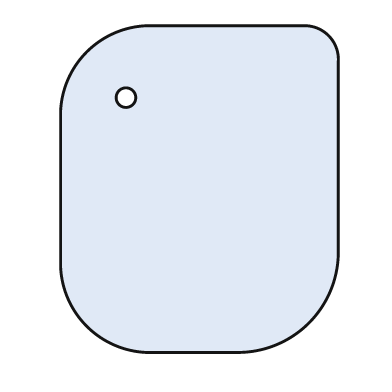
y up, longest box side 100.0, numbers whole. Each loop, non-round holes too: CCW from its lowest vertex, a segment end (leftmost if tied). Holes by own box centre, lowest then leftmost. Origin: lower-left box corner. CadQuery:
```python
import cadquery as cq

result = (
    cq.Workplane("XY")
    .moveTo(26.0, 0.0)
    .lineTo(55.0, 0.0)
    .threePointArc((76.0, 9.0), (85.0, 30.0))
    .lineTo(85.0, 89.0)
    .threePointArc((82.0, 97.0), (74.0, 100.0))
    .lineTo(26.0, 100.0)
    .threePointArc((8.0, 92.0), (0.0, 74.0))
    .lineTo(0.0, 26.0)
    .threePointArc((8.0, 8.0), (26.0, 0.0))
    .close()
    .moveTo(20.0, 78.0)
    .circle(3.0)
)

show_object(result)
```